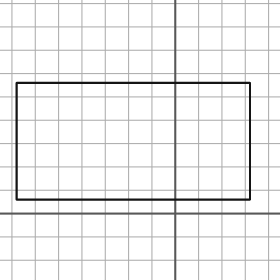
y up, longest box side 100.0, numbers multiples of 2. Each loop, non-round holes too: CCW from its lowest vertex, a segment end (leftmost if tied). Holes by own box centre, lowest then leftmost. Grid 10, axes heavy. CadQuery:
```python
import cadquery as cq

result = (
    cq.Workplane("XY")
    .moveTo(-68.0, 6.0)
    .lineTo(32.0, 6.0)
    .lineTo(32.0, 56.0)
    .lineTo(-68.0, 56.0)
    .close()
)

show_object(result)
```